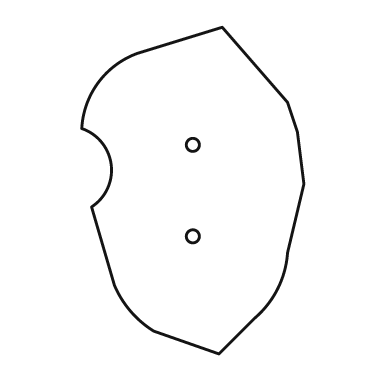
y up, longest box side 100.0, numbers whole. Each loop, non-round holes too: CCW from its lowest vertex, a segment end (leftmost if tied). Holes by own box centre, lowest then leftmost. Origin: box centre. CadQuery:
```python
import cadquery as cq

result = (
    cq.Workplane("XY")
    .moveTo(8.0, -50.0)
    .lineTo(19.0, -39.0)
    .threePointArc((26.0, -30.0), (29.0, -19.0))
    .lineTo(34.0, 2.0)
    .lineTo(32.0, 18.0)
    .lineTo(29.0, 27.0)
    .lineTo(9.0, 50.0)
    .lineTo(-17.0, 42.0)
    .threePointArc((-29.0, 33.0), (-34.0, 19.0))
    .threePointArc((-25.0, 8.0), (-31.0, -5.0))
    .lineTo(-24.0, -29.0)
    .threePointArc((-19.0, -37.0), (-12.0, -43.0))
    .close()
    .moveTo(0.0, -14.0)
    .circle(2.0)
    .moveTo(0.0, 14.0)
    .circle(2.0)
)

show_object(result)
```